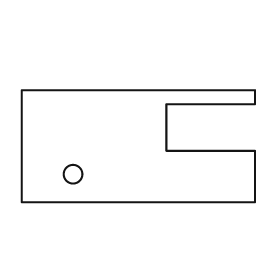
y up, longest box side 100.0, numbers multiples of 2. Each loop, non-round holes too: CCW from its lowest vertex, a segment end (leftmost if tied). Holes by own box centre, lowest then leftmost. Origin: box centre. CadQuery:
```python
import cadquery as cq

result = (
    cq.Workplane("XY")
    .moveTo(-50.0, -24.0)
    .lineTo(50.0, -24.0)
    .lineTo(50.0, -2.0)
    .lineTo(12.0, -2.0)
    .lineTo(12.0, 18.0)
    .lineTo(50.0, 18.0)
    .lineTo(50.0, 24.0)
    .lineTo(-50.0, 24.0)
    .close()
    .moveTo(-28.0, -12.0)
    .circle(4.0)
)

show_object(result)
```